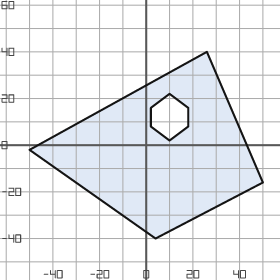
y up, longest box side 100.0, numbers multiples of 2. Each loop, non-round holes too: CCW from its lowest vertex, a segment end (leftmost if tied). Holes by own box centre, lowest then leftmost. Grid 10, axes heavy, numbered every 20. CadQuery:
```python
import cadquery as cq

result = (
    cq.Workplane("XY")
    .moveTo(4.0, -40.0)
    .lineTo(50.0, -16.0)
    .lineTo(26.0, 40.0)
    .lineTo(-50.0, -2.0)
    .close()
    .moveTo(10.0, 2.0)
    .lineTo(18.0, 8.0)
    .lineTo(18.0, 16.0)
    .lineTo(10.0, 22.0)
    .lineTo(2.0, 16.0)
    .lineTo(2.0, 8.0)
    .close()
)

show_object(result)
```